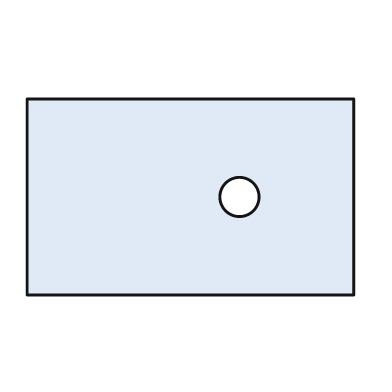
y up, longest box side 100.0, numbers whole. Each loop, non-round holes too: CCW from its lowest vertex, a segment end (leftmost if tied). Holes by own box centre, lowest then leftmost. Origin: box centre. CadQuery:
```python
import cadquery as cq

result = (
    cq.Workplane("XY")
    .moveTo(-50.0, -30.0)
    .lineTo(50.0, -30.0)
    .lineTo(50.0, 30.0)
    .lineTo(-50.0, 30.0)
    .close()
    .moveTo(15.0, 0.0)
    .circle(6.0)
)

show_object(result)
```